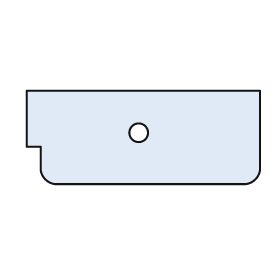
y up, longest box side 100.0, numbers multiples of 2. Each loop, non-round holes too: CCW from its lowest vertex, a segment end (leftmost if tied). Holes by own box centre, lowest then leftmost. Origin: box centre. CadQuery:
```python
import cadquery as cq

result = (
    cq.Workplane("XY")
    .moveTo(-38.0, -20.0)
    .lineTo(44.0, -20.0)
    .threePointArc((48.0, -18.0), (50.0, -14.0))
    .lineTo(50.0, 20.0)
    .lineTo(-50.0, 20.0)
    .lineTo(-50.0, -4.0)
    .lineTo(-44.0, -4.0)
    .lineTo(-44.0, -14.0)
    .threePointArc((-42.0, -18.0), (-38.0, -20.0))
    .close()
    .moveTo(-2.0, 2.0)
    .circle(4.0)
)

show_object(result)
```